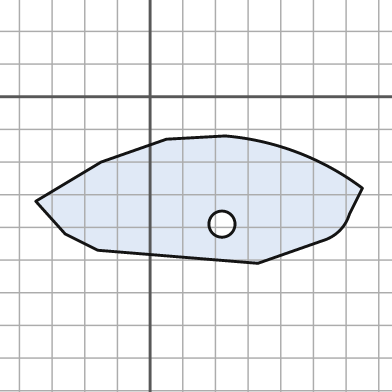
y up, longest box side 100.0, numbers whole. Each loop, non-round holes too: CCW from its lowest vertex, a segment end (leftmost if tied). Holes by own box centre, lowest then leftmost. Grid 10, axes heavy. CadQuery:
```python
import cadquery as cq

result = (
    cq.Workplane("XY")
    .moveTo(33.0, -51.0)
    .lineTo(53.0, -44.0)
    .threePointArc((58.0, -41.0), (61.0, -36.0))
    .lineTo(65.0, -28.0)
    .threePointArc((45.0, -17.0), (23.0, -12.0))
    .lineTo(5.0, -13.0)
    .lineTo(-15.0, -20.0)
    .lineTo(-35.0, -32.0)
    .lineTo(-26.0, -42.0)
    .lineTo(-16.0, -47.0)
    .close()
    .moveTo(22.0, -39.0)
    .circle(4.0)
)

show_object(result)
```